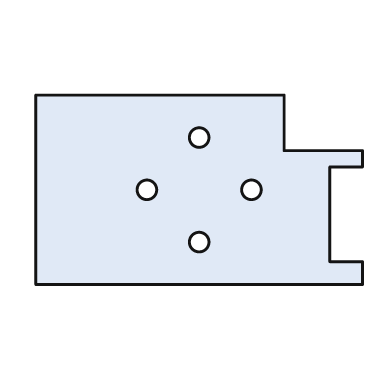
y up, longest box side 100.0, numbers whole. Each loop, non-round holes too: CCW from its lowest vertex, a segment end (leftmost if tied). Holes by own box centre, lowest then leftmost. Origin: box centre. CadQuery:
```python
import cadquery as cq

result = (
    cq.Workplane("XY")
    .moveTo(-50.0, -29.0)
    .lineTo(50.0, -29.0)
    .lineTo(50.0, -22.0)
    .lineTo(40.0, -22.0)
    .lineTo(40.0, 7.0)
    .lineTo(50.0, 7.0)
    .lineTo(50.0, 12.0)
    .lineTo(26.0, 12.0)
    .lineTo(26.0, 29.0)
    .lineTo(-50.0, 29.0)
    .close()
    .moveTo(0.0, -16.0)
    .circle(3.0)
    .moveTo(-16.0, 0.0)
    .circle(3.0)
    .moveTo(16.0, 0.0)
    .circle(3.0)
    .moveTo(0.0, 16.0)
    .circle(3.0)
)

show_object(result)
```